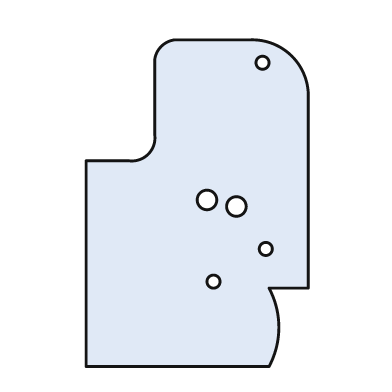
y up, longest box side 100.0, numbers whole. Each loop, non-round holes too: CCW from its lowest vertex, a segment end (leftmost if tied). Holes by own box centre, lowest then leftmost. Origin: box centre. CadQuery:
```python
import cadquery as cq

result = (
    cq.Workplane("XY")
    .moveTo(-34.0, -50.0)
    .lineTo(22.0, -50.0)
    .threePointArc((25.0, -38.0), (22.0, -26.0))
    .lineTo(34.0, -26.0)
    .lineTo(34.0, 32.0)
    .threePointArc((29.0, 45.0), (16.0, 50.0))
    .lineTo(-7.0, 50.0)
    .threePointArc((-11.0, 48.0), (-13.0, 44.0))
    .lineTo(-13.0, 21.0)
    .threePointArc((-15.0, 15.0), (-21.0, 13.0))
    .lineTo(-34.0, 13.0)
    .close()
    .moveTo(5.0, -24.0)
    .circle(2.0)
    .moveTo(21.0, -14.0)
    .circle(2.0)
    .moveTo(12.0, -1.0)
    .circle(3.0)
    .moveTo(3.0, 1.0)
    .circle(3.0)
    .moveTo(20.0, 43.0)
    .circle(2.0)
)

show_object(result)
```